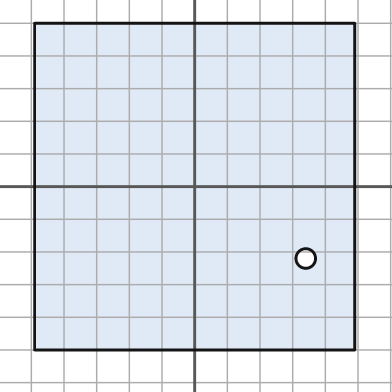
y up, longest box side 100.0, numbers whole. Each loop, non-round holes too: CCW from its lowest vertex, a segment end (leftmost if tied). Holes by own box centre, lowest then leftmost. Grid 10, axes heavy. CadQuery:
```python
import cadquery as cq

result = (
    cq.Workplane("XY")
    .moveTo(-49.0, -50.0)
    .lineTo(49.0, -50.0)
    .lineTo(49.0, 50.0)
    .lineTo(-49.0, 50.0)
    .close()
    .moveTo(34.0, -22.0)
    .circle(3.0)
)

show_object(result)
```